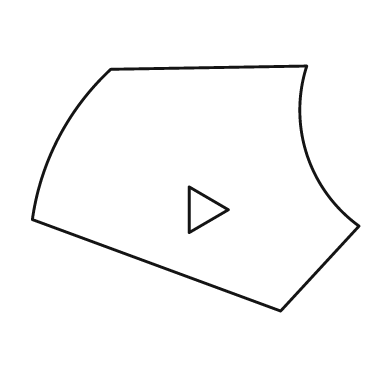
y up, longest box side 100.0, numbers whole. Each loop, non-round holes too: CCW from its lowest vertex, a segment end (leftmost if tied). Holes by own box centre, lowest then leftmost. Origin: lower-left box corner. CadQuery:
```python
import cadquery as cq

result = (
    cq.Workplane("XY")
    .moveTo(76.0, 0.0)
    .lineTo(100.0, 26.0)
    .threePointArc((84.0, 48.0), (84.0, 75.0))
    .lineTo(24.0, 74.0)
    .threePointArc((8.0, 53.0), (0.0, 28.0))
    .close()
    .moveTo(48.0, 24.0)
    .lineTo(60.0, 31.0)
    .lineTo(48.0, 38.0)
    .close()
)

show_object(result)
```